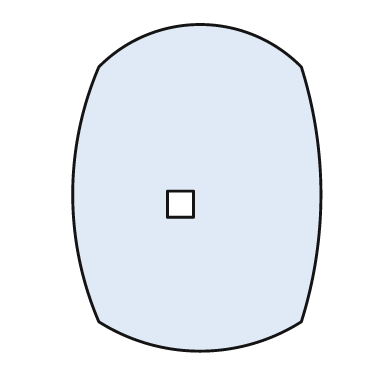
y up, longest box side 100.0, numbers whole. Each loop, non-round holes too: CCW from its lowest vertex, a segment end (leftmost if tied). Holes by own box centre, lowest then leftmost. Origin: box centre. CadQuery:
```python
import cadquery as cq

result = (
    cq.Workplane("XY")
    .moveTo(-30.0, -41.0)
    .threePointArc((1.0, -50.0), (32.0, -41.0))
    .threePointArc((38.0, -2.0), (32.0, 37.0))
    .threePointArc((1.0, 50.0), (-30.0, 37.0))
    .threePointArc((-38.0, -2.0), (-30.0, -41.0))
    .close()
    .moveTo(-9.0, -9.0)
    .lineTo(-1.0, -9.0)
    .lineTo(-1.0, -1.0)
    .lineTo(-9.0, -1.0)
    .close()
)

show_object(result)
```